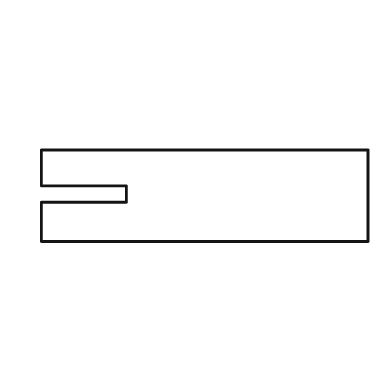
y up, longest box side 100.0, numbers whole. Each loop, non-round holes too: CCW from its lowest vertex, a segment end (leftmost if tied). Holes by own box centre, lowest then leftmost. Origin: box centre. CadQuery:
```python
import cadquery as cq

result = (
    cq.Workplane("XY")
    .moveTo(-50.0, -14.0)
    .lineTo(50.0, -14.0)
    .lineTo(50.0, 14.0)
    .lineTo(-50.0, 14.0)
    .lineTo(-50.0, 3.0)
    .lineTo(-24.0, 3.0)
    .lineTo(-24.0, -2.0)
    .lineTo(-50.0, -2.0)
    .close()
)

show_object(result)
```